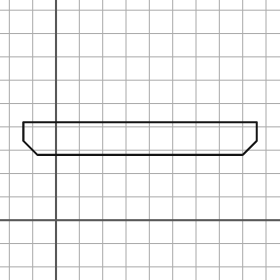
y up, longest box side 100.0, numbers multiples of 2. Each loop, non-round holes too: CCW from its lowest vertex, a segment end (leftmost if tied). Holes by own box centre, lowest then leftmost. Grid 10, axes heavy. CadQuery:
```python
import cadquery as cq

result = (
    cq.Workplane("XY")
    .moveTo(-8.0, 28.0)
    .lineTo(80.0, 28.0)
    .lineTo(86.0, 34.0)
    .lineTo(86.0, 42.0)
    .lineTo(-14.0, 42.0)
    .lineTo(-14.0, 34.0)
    .close()
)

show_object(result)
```